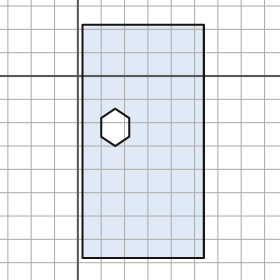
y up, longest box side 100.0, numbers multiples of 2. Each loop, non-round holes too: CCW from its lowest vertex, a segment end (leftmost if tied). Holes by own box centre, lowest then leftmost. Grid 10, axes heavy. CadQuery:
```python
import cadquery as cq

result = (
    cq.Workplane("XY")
    .moveTo(2.0, -78.0)
    .lineTo(54.0, -78.0)
    .lineTo(54.0, 22.0)
    .lineTo(2.0, 22.0)
    .close()
    .moveTo(16.0, -30.0)
    .lineTo(22.0, -26.0)
    .lineTo(22.0, -18.0)
    .lineTo(16.0, -14.0)
    .lineTo(10.0, -18.0)
    .lineTo(10.0, -26.0)
    .close()
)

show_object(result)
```